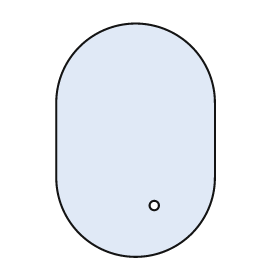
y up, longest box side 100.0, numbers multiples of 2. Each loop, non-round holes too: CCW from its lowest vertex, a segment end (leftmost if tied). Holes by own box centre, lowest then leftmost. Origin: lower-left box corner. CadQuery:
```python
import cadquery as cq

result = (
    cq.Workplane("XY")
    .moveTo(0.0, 34.0)
    .threePointArc((34.0, 0.0), (68.0, 34.0))
    .lineTo(68.0, 66.0)
    .threePointArc((34.0, 100.0), (0.0, 66.0))
    .close()
    .moveTo(42.0, 22.0)
    .circle(2.0)
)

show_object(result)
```